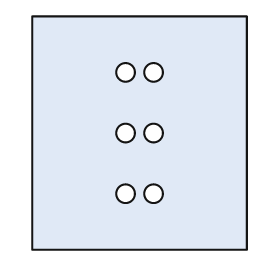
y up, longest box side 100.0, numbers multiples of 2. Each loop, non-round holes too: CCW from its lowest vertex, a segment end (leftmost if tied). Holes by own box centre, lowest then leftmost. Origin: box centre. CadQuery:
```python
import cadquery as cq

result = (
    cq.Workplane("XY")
    .moveTo(-46.0, -50.0)
    .lineTo(46.0, -50.0)
    .lineTo(46.0, 50.0)
    .lineTo(-46.0, 50.0)
    .close()
    .moveTo(-6.0, -26.0)
    .circle(4.0)
    .moveTo(6.0, -26.0)
    .circle(4.0)
    .moveTo(-6.0, 0.0)
    .circle(4.0)
    .moveTo(6.0, 0.0)
    .circle(4.0)
    .moveTo(-6.0, 26.0)
    .circle(4.0)
    .moveTo(6.0, 26.0)
    .circle(4.0)
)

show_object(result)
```